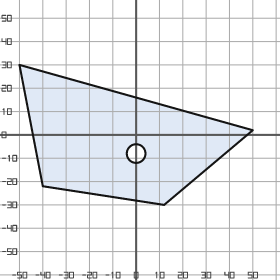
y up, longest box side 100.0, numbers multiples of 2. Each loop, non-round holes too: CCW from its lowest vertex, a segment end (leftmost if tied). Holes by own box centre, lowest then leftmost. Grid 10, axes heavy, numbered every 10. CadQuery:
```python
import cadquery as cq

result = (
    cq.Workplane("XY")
    .moveTo(12.0, -30.0)
    .lineTo(50.0, 2.0)
    .lineTo(-50.0, 30.0)
    .lineTo(-40.0, -22.0)
    .close()
    .moveTo(0.0, -8.0)
    .circle(4.0)
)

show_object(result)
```